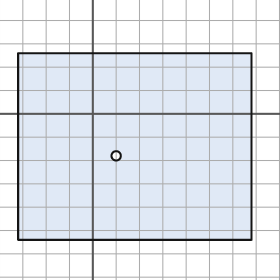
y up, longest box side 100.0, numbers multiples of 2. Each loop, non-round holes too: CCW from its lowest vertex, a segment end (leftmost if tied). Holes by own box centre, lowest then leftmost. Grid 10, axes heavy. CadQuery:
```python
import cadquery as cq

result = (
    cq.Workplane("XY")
    .moveTo(-32.0, -54.0)
    .lineTo(68.0, -54.0)
    .lineTo(68.0, 26.0)
    .lineTo(-32.0, 26.0)
    .close()
    .moveTo(10.0, -18.0)
    .circle(2.0)
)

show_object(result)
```